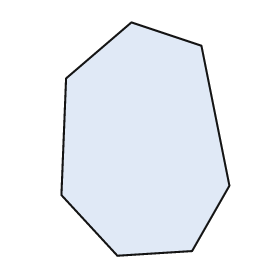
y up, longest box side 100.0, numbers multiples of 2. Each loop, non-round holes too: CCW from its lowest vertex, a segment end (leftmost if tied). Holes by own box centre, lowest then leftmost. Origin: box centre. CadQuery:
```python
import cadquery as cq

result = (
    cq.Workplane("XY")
    .moveTo(-12.0, -50.0)
    .lineTo(20.0, -48.0)
    .lineTo(36.0, -20.0)
    .lineTo(24.0, 40.0)
    .lineTo(-6.0, 50.0)
    .lineTo(-34.0, 26.0)
    .lineTo(-36.0, -24.0)
    .close()
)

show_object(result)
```